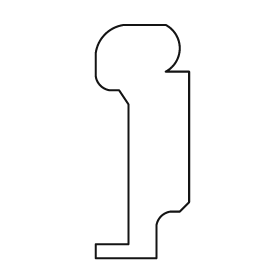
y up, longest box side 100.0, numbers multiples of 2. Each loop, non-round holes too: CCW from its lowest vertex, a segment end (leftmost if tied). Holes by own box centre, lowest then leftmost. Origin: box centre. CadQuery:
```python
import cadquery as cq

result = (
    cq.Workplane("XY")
    .moveTo(-20.0, -50.0)
    .lineTo(6.0, -50.0)
    .lineTo(6.0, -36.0)
    .threePointArc((8.0, -32.0), (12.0, -30.0))
    .lineTo(16.0, -30.0)
    .lineTo(20.0, -26.0)
    .lineTo(20.0, 30.0)
    .lineTo(10.0, 30.0)
    .threePointArc((16.0, 40.0), (10.0, 50.0))
    .lineTo(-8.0, 50.0)
    .threePointArc((-16.0, 46.0), (-20.0, 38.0))
    .lineTo(-20.0, 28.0)
    .threePointArc((-18.0, 24.0), (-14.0, 22.0))
    .lineTo(-10.0, 22.0)
    .lineTo(-6.0, 16.0)
    .lineTo(-6.0, -44.0)
    .lineTo(-20.0, -44.0)
    .close()
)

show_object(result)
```